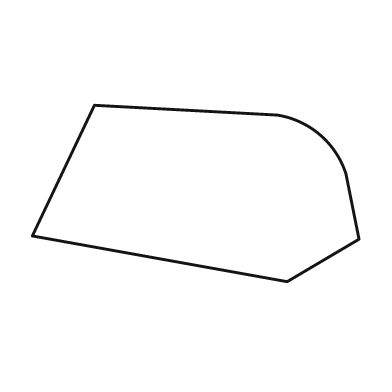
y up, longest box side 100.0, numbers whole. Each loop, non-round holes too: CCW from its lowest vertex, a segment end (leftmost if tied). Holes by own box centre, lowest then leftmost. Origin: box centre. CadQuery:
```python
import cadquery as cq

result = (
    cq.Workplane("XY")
    .moveTo(28.0, -27.0)
    .lineTo(50.0, -14.0)
    .lineTo(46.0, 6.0)
    .threePointArc((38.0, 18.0), (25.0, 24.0))
    .lineTo(-31.0, 27.0)
    .lineTo(-50.0, -13.0)
    .close()
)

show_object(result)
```